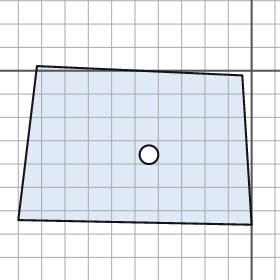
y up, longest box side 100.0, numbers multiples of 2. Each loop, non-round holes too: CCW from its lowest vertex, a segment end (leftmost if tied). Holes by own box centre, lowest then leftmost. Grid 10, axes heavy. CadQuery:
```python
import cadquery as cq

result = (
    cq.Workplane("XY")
    .moveTo(0.0, -66.0)
    .lineTo(-4.0, -2.0)
    .lineTo(-92.0, 2.0)
    .lineTo(-100.0, -64.0)
    .close()
    .moveTo(-44.0, -36.0)
    .circle(4.0)
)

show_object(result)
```